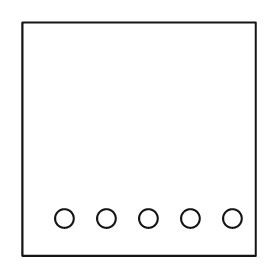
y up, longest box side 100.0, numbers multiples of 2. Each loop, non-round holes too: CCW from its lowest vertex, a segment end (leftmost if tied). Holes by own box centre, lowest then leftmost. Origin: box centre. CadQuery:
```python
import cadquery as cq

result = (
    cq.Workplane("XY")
    .moveTo(-50.0, -50.0)
    .lineTo(50.0, -50.0)
    .lineTo(50.0, 50.0)
    .lineTo(-50.0, 50.0)
    .close()
    .moveTo(-32.0, -34.0)
    .circle(4.0)
    .moveTo(-14.0, -34.0)
    .circle(4.0)
    .moveTo(4.0, -34.0)
    .circle(4.0)
    .moveTo(22.0, -34.0)
    .circle(4.0)
    .moveTo(40.0, -34.0)
    .circle(4.0)
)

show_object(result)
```